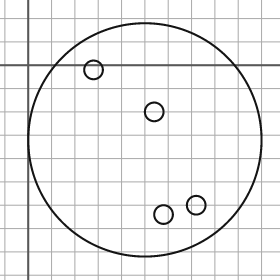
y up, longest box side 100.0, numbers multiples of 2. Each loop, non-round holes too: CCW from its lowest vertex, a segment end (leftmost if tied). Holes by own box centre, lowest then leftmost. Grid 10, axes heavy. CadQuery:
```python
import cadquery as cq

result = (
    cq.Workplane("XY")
    .moveTo(50.0, -32.0)
    .circle(50.0)
    .moveTo(58.0, -64.0)
    .circle(4.0)
    .moveTo(72.0, -60.0)
    .circle(4.0)
    .moveTo(54.0, -20.0)
    .circle(4.0)
    .moveTo(28.0, -2.0)
    .circle(4.0)
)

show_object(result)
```